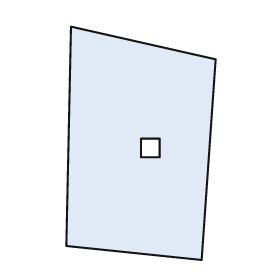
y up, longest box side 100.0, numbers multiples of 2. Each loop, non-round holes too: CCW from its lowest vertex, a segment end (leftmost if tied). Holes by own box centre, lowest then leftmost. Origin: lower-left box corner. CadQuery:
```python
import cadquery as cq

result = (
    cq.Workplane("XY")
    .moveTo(58.0, 0.0)
    .lineTo(64.0, 86.0)
    .lineTo(2.0, 100.0)
    .lineTo(0.0, 6.0)
    .close()
    .moveTo(32.0, 44.0)
    .lineTo(40.0, 44.0)
    .lineTo(40.0, 52.0)
    .lineTo(32.0, 52.0)
    .close()
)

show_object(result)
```